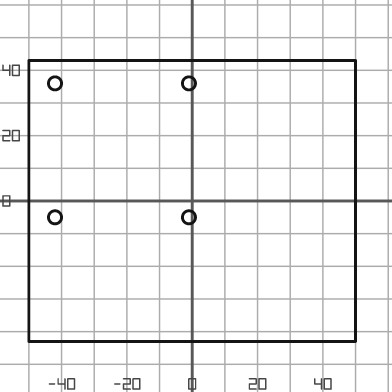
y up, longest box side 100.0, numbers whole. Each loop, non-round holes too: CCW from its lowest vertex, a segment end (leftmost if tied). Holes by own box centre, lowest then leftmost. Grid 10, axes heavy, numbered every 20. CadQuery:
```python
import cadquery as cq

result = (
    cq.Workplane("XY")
    .moveTo(-50.0, -43.0)
    .lineTo(50.0, -43.0)
    .lineTo(50.0, 43.0)
    .lineTo(-50.0, 43.0)
    .close()
    .moveTo(-42.0, -5.0)
    .circle(2.0)
    .moveTo(-1.0, -5.0)
    .circle(2.0)
    .moveTo(-42.0, 36.0)
    .circle(2.0)
    .moveTo(-1.0, 36.0)
    .circle(2.0)
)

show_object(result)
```